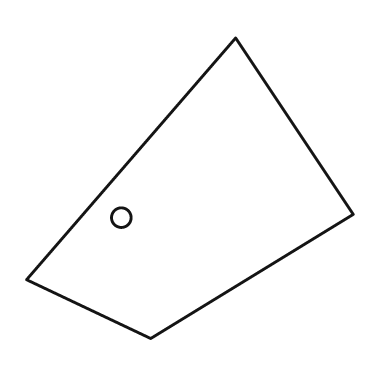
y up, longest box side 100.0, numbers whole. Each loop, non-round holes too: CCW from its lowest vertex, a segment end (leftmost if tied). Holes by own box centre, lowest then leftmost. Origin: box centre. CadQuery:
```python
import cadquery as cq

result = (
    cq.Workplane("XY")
    .moveTo(-12.0, -46.0)
    .lineTo(50.0, -8.0)
    .lineTo(14.0, 46.0)
    .lineTo(-50.0, -28.0)
    .close()
    .moveTo(-21.0, -9.0)
    .circle(3.0)
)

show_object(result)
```